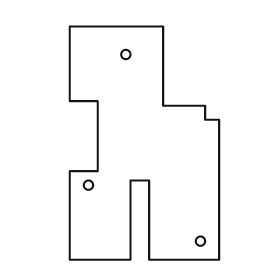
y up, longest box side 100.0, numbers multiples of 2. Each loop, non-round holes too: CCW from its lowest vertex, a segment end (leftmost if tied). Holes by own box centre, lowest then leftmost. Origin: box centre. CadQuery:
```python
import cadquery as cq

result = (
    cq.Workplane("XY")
    .moveTo(-32.0, -50.0)
    .lineTo(-6.0, -50.0)
    .lineTo(-6.0, -16.0)
    .lineTo(2.0, -16.0)
    .lineTo(2.0, -50.0)
    .lineTo(32.0, -50.0)
    .lineTo(32.0, 10.0)
    .lineTo(26.0, 10.0)
    .lineTo(26.0, 16.0)
    .lineTo(8.0, 16.0)
    .lineTo(8.0, 50.0)
    .lineTo(-32.0, 50.0)
    .lineTo(-32.0, 18.0)
    .lineTo(-20.0, 18.0)
    .lineTo(-20.0, -12.0)
    .lineTo(-32.0, -12.0)
    .close()
    .moveTo(24.0, -42.0)
    .circle(2.0)
    .moveTo(-24.0, -18.0)
    .circle(2.0)
    .moveTo(-8.0, 38.0)
    .circle(2.0)
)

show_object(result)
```